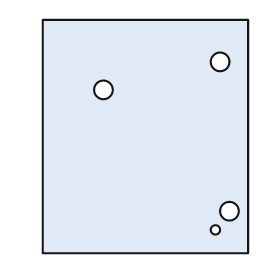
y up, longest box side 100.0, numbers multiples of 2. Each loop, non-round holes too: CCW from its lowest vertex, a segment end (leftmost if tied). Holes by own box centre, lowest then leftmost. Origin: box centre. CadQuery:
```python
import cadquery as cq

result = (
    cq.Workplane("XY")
    .moveTo(-44.0, -50.0)
    .lineTo(44.0, -50.0)
    .lineTo(44.0, 50.0)
    .lineTo(-44.0, 50.0)
    .close()
    .moveTo(30.0, -40.0)
    .circle(2.0)
    .moveTo(36.0, -32.0)
    .circle(4.0)
    .moveTo(-18.0, 20.0)
    .circle(4.0)
    .moveTo(32.0, 32.0)
    .circle(4.0)
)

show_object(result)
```